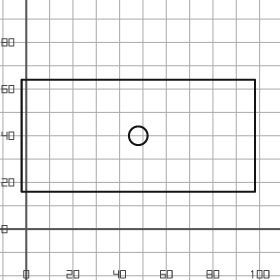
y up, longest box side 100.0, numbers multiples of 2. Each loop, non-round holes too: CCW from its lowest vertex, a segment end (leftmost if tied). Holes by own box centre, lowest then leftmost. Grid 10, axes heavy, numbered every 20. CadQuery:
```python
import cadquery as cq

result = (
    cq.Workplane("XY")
    .moveTo(-2.0, 16.0)
    .lineTo(98.0, 16.0)
    .lineTo(98.0, 64.0)
    .lineTo(-2.0, 64.0)
    .close()
    .moveTo(48.0, 40.0)
    .circle(4.0)
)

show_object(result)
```